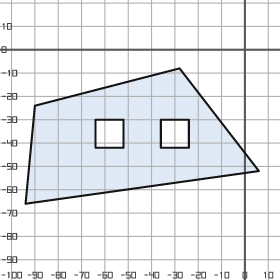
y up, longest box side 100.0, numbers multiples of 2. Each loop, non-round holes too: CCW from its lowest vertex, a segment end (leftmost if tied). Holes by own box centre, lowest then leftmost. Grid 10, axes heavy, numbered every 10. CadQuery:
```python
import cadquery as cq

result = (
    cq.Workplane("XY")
    .moveTo(-94.0, -66.0)
    .lineTo(6.0, -52.0)
    .lineTo(-28.0, -8.0)
    .lineTo(-90.0, -24.0)
    .close()
    .moveTo(-64.0, -42.0)
    .lineTo(-52.0, -42.0)
    .lineTo(-52.0, -30.0)
    .lineTo(-64.0, -30.0)
    .close()
    .moveTo(-36.0, -42.0)
    .lineTo(-24.0, -42.0)
    .lineTo(-24.0, -30.0)
    .lineTo(-36.0, -30.0)
    .close()
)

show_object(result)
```